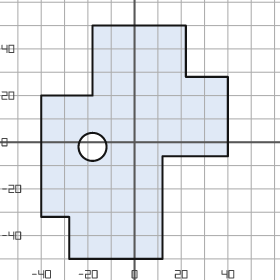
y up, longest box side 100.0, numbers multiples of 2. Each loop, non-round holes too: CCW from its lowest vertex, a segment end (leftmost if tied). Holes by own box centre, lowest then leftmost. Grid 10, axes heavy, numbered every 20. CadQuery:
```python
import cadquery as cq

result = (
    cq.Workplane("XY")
    .moveTo(-28.0, -50.0)
    .lineTo(12.0, -50.0)
    .lineTo(12.0, -6.0)
    .lineTo(40.0, -6.0)
    .lineTo(40.0, 28.0)
    .lineTo(22.0, 28.0)
    .lineTo(22.0, 50.0)
    .lineTo(-18.0, 50.0)
    .lineTo(-18.0, 20.0)
    .lineTo(-40.0, 20.0)
    .lineTo(-40.0, -32.0)
    .lineTo(-28.0, -32.0)
    .close()
    .moveTo(-18.0, -2.0)
    .circle(6.0)
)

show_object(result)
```